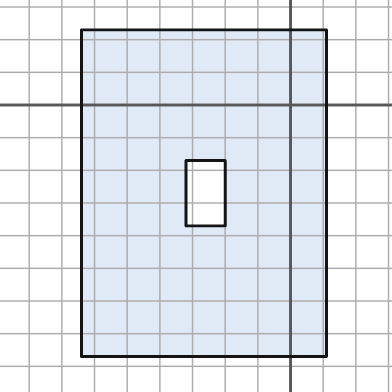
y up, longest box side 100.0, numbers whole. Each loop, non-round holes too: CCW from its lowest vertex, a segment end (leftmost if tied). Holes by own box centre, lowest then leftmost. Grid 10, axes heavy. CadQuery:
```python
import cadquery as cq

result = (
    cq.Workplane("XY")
    .moveTo(-64.0, -77.0)
    .lineTo(11.0, -77.0)
    .lineTo(11.0, 23.0)
    .lineTo(-64.0, 23.0)
    .close()
    .moveTo(-32.0, -37.0)
    .lineTo(-20.0, -37.0)
    .lineTo(-20.0, -17.0)
    .lineTo(-32.0, -17.0)
    .close()
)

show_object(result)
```